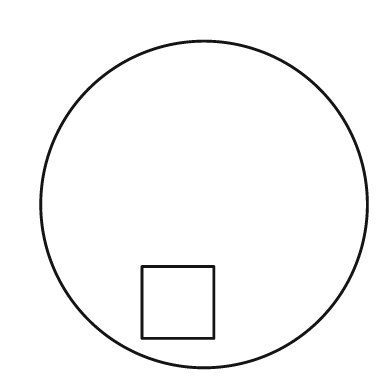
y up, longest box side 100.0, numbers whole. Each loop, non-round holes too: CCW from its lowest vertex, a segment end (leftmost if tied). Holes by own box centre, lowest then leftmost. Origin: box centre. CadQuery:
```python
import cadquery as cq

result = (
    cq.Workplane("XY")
    .moveTo(0.0, 0.0)
    .circle(50.0)
    .moveTo(-19.0, -41.0)
    .lineTo(3.0, -41.0)
    .lineTo(3.0, -19.0)
    .lineTo(-19.0, -19.0)
    .close()
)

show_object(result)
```